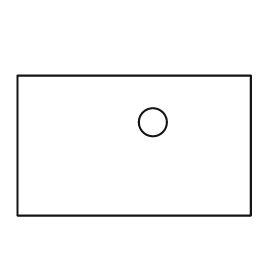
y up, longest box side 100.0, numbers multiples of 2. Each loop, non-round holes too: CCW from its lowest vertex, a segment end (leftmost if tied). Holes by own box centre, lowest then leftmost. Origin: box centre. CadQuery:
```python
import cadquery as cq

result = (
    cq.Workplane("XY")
    .moveTo(-50.0, -30.0)
    .lineTo(50.0, -30.0)
    .lineTo(50.0, 30.0)
    .lineTo(-50.0, 30.0)
    .close()
    .moveTo(8.0, 10.0)
    .circle(6.0)
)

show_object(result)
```